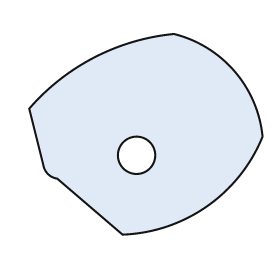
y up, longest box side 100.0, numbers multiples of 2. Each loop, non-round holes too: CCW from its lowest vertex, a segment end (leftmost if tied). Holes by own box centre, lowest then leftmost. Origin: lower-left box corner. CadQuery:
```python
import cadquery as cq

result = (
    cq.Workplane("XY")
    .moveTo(40.0, 0.0)
    .threePointArc((76.0, 12.0), (100.0, 42.0))
    .threePointArc((88.0, 70.0), (62.0, 86.0))
    .threePointArc((28.0, 76.0), (0.0, 54.0))
    .lineTo(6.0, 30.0)
    .threePointArc((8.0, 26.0), (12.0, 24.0))
    .close()
    .moveTo(46.0, 34.0)
    .circle(8.0)
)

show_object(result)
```